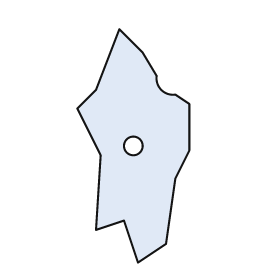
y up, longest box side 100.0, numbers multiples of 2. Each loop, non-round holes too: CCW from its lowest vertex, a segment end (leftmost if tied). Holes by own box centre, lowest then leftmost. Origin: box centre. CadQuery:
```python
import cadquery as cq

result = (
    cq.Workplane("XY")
    .moveTo(2.0, -50.0)
    .lineTo(14.0, -42.0)
    .lineTo(18.0, -14.0)
    .lineTo(24.0, -2.0)
    .lineTo(24.0, 18.0)
    .lineTo(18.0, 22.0)
    .threePointArc((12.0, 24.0), (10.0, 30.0))
    .lineTo(4.0, 40.0)
    .lineTo(-6.0, 50.0)
    .lineTo(-16.0, 24.0)
    .lineTo(-24.0, 16.0)
    .lineTo(-14.0, -4.0)
    .lineTo(-16.0, -36.0)
    .lineTo(-4.0, -32.0)
    .close()
    .moveTo(0.0, 0.0)
    .circle(4.0)
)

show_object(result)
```